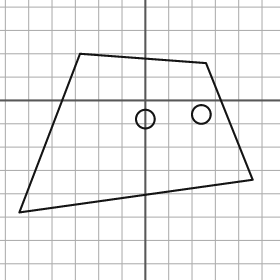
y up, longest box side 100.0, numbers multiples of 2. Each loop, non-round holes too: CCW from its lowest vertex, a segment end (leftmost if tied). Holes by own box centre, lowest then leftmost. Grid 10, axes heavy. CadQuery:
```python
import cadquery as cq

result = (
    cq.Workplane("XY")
    .moveTo(-54.0, -48.0)
    .lineTo(46.0, -34.0)
    .lineTo(26.0, 16.0)
    .lineTo(-28.0, 20.0)
    .close()
    .moveTo(0.0, -8.0)
    .circle(4.0)
    .moveTo(24.0, -6.0)
    .circle(4.0)
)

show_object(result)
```